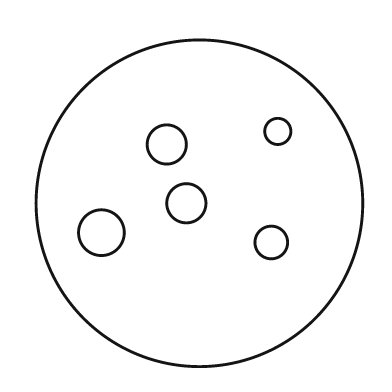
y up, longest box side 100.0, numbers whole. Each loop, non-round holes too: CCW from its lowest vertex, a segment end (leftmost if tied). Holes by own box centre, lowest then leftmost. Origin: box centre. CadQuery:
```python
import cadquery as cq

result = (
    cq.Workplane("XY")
    .moveTo(0.0, 0.0)
    .circle(50.0)
    .moveTo(22.0, -12.0)
    .circle(5.0)
    .moveTo(-30.0, -9.0)
    .circle(7.0)
    .moveTo(-4.0, 0.0)
    .circle(6.0)
    .moveTo(-10.0, 18.0)
    .circle(6.0)
    .moveTo(24.0, 22.0)
    .circle(4.0)
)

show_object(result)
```